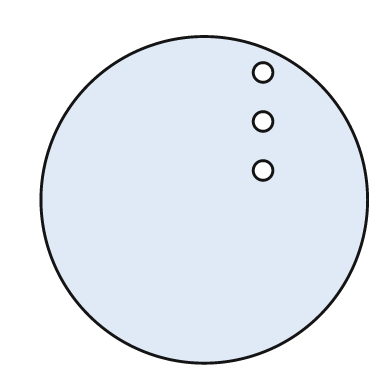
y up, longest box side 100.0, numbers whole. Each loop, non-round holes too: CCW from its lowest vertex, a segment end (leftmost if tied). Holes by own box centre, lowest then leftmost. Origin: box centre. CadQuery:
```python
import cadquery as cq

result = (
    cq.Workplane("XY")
    .moveTo(0.0, 0.0)
    .circle(50.0)
    .moveTo(18.0, 9.0)
    .circle(3.0)
    .moveTo(18.0, 24.0)
    .circle(3.0)
    .moveTo(18.0, 39.0)
    .circle(3.0)
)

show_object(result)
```